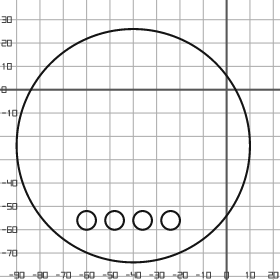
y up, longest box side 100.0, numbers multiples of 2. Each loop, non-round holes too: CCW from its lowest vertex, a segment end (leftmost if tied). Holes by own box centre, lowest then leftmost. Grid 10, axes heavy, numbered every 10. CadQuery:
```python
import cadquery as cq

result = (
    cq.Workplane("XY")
    .moveTo(-40.0, -24.0)
    .circle(50.0)
    .moveTo(-60.0, -56.0)
    .circle(4.0)
    .moveTo(-48.0, -56.0)
    .circle(4.0)
    .moveTo(-36.0, -56.0)
    .circle(4.0)
    .moveTo(-24.0, -56.0)
    .circle(4.0)
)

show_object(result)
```